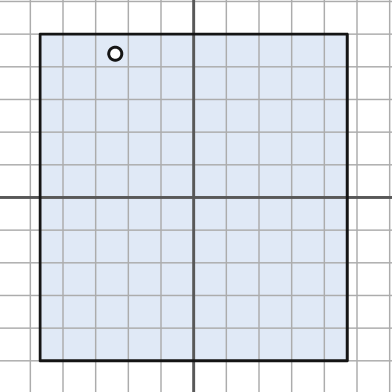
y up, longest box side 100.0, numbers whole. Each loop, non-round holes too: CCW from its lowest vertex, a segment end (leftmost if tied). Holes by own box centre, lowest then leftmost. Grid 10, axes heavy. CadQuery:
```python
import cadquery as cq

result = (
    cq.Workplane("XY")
    .moveTo(-47.0, -50.0)
    .lineTo(47.0, -50.0)
    .lineTo(47.0, 50.0)
    .lineTo(-47.0, 50.0)
    .close()
    .moveTo(-24.0, 44.0)
    .circle(2.0)
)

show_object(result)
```